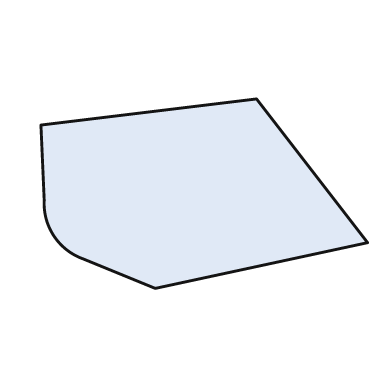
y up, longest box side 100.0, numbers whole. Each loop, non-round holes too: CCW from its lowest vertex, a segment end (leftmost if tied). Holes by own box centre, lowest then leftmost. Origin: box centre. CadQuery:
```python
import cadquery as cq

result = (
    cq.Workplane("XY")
    .moveTo(-15.0, -29.0)
    .lineTo(50.0, -15.0)
    .lineTo(16.0, 29.0)
    .lineTo(-50.0, 21.0)
    .lineTo(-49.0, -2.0)
    .threePointArc((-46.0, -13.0), (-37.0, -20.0))
    .close()
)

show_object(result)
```